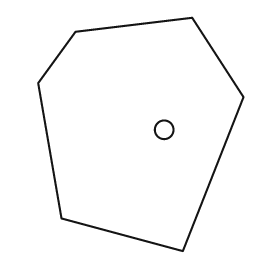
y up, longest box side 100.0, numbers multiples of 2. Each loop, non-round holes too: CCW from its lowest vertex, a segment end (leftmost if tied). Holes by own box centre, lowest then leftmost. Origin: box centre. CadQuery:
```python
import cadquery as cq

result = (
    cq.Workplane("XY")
    .moveTo(18.0, -50.0)
    .lineTo(44.0, 16.0)
    .lineTo(22.0, 50.0)
    .lineTo(-28.0, 44.0)
    .lineTo(-44.0, 22.0)
    .lineTo(-34.0, -36.0)
    .close()
    .moveTo(10.0, 2.0)
    .circle(4.0)
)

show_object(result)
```